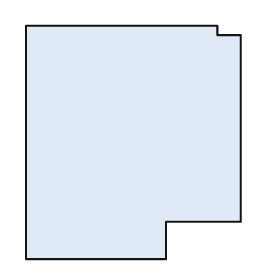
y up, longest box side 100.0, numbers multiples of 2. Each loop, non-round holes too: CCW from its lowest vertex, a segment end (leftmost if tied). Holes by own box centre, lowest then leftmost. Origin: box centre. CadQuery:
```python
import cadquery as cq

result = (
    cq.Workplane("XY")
    .moveTo(-46.0, -50.0)
    .lineTo(14.0, -50.0)
    .lineTo(14.0, -34.0)
    .lineTo(46.0, -34.0)
    .lineTo(46.0, 46.0)
    .lineTo(36.0, 46.0)
    .lineTo(36.0, 50.0)
    .lineTo(-46.0, 50.0)
    .close()
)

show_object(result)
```